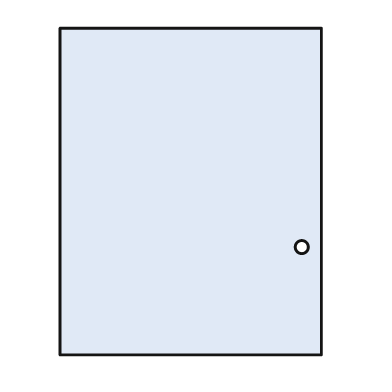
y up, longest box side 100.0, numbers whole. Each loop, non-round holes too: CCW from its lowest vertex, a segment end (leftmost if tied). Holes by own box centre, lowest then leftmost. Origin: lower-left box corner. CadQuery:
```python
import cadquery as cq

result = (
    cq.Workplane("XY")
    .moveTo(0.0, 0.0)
    .lineTo(80.0, 0.0)
    .lineTo(80.0, 100.0)
    .lineTo(0.0, 100.0)
    .close()
    .moveTo(74.0, 33.0)
    .circle(2.0)
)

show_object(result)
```